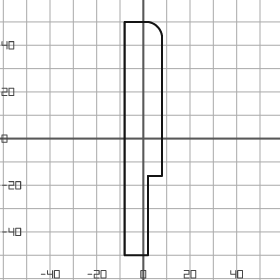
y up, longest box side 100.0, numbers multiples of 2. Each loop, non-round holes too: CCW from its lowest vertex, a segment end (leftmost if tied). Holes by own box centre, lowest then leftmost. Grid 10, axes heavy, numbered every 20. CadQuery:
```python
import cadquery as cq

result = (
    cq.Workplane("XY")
    .moveTo(-8.0, -50.0)
    .lineTo(2.0, -50.0)
    .lineTo(2.0, -16.0)
    .lineTo(8.0, -16.0)
    .lineTo(8.0, 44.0)
    .threePointArc((6.0, 48.0), (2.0, 50.0))
    .lineTo(-8.0, 50.0)
    .close()
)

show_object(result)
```